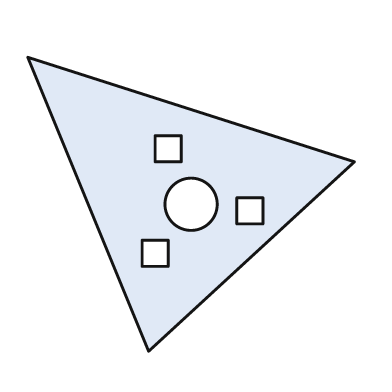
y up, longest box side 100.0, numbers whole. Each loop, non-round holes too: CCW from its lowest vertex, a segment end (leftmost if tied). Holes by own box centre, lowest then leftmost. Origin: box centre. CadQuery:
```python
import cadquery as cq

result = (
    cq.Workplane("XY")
    .moveTo(-13.0, -45.0)
    .lineTo(50.0, 13.0)
    .lineTo(-50.0, 45.0)
    .close()
    .moveTo(-15.0, -19.0)
    .lineTo(-7.0, -19.0)
    .lineTo(-7.0, -11.0)
    .lineTo(-15.0, -11.0)
    .close()
    .moveTo(14.0, -6.0)
    .lineTo(22.0, -6.0)
    .lineTo(22.0, 2.0)
    .lineTo(14.0, 2.0)
    .close()
    .moveTo(0.0, 0.0)
    .circle(8.0)
    .moveTo(-11.0, 13.0)
    .lineTo(-3.0, 13.0)
    .lineTo(-3.0, 21.0)
    .lineTo(-11.0, 21.0)
    .close()
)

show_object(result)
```